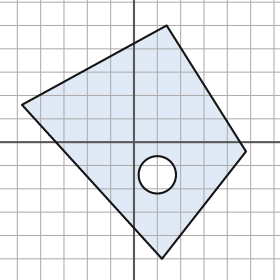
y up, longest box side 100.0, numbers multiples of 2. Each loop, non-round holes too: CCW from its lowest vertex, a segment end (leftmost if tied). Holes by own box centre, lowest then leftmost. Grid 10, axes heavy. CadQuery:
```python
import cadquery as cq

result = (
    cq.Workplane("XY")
    .moveTo(12.0, -50.0)
    .lineTo(48.0, -4.0)
    .lineTo(14.0, 50.0)
    .lineTo(-48.0, 16.0)
    .close()
    .moveTo(10.0, -14.0)
    .circle(8.0)
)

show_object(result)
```